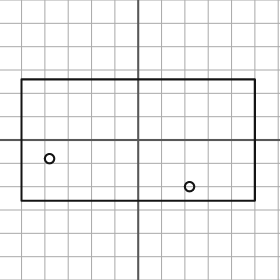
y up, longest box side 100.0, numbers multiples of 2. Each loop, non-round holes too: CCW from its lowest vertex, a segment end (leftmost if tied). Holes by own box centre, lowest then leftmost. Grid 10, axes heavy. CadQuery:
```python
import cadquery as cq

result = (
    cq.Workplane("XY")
    .moveTo(-50.0, -26.0)
    .lineTo(50.0, -26.0)
    .lineTo(50.0, 26.0)
    .lineTo(-50.0, 26.0)
    .close()
    .moveTo(22.0, -20.0)
    .circle(2.0)
    .moveTo(-38.0, -8.0)
    .circle(2.0)
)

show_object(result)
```